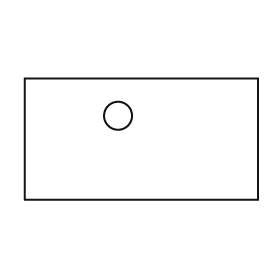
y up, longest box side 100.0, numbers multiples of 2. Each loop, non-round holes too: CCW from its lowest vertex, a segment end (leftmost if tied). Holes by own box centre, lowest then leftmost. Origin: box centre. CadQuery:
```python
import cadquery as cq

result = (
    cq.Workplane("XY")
    .moveTo(-50.0, -26.0)
    .lineTo(50.0, -26.0)
    .lineTo(50.0, 26.0)
    .lineTo(-50.0, 26.0)
    .close()
    .moveTo(-10.0, 10.0)
    .circle(6.0)
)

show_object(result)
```